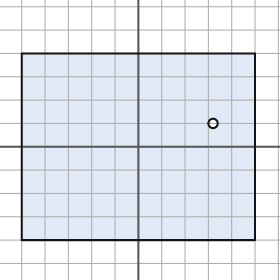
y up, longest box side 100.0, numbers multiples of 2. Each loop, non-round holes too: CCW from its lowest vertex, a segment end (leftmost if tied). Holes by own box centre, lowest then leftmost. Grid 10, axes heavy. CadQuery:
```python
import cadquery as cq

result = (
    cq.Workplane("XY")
    .moveTo(-50.0, -40.0)
    .lineTo(50.0, -40.0)
    .lineTo(50.0, 40.0)
    .lineTo(-50.0, 40.0)
    .close()
    .moveTo(32.0, 10.0)
    .circle(2.0)
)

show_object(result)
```